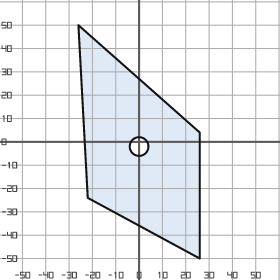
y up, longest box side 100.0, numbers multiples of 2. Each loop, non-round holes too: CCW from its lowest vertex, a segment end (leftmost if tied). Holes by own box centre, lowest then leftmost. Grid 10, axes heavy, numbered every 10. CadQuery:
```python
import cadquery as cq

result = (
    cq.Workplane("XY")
    .moveTo(26.0, -50.0)
    .lineTo(26.0, 4.0)
    .lineTo(-26.0, 50.0)
    .lineTo(-22.0, -24.0)
    .close()
    .moveTo(0.0, -2.0)
    .circle(4.0)
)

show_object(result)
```